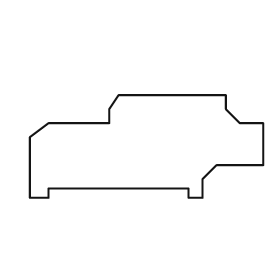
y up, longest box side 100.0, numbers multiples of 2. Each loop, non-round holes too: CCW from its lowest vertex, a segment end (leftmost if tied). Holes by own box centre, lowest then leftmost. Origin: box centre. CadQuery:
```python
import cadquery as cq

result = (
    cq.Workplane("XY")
    .moveTo(-50.0, -22.0)
    .lineTo(-42.0, -22.0)
    .lineTo(-42.0, -18.0)
    .lineTo(18.0, -18.0)
    .lineTo(18.0, -22.0)
    .lineTo(24.0, -22.0)
    .lineTo(24.0, -14.0)
    .lineTo(30.0, -8.0)
    .lineTo(50.0, -8.0)
    .lineTo(50.0, 10.0)
    .lineTo(40.0, 10.0)
    .lineTo(34.0, 16.0)
    .lineTo(34.0, 22.0)
    .lineTo(-12.0, 22.0)
    .lineTo(-16.0, 16.0)
    .lineTo(-16.0, 10.0)
    .lineTo(-42.0, 10.0)
    .lineTo(-50.0, 4.0)
    .close()
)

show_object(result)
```